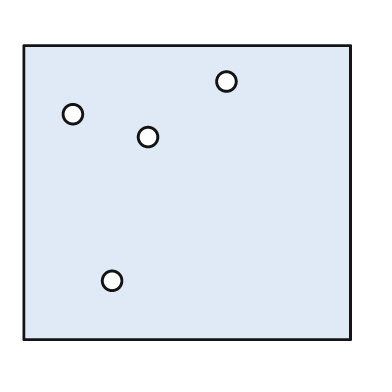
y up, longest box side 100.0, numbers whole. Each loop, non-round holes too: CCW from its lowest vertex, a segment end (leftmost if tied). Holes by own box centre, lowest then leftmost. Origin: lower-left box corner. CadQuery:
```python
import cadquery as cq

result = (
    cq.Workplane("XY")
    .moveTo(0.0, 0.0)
    .lineTo(100.0, 0.0)
    .lineTo(100.0, 90.0)
    .lineTo(0.0, 90.0)
    .close()
    .moveTo(27.0, 18.0)
    .circle(3.0)
    .moveTo(38.0, 62.0)
    .circle(3.0)
    .moveTo(15.0, 69.0)
    .circle(3.0)
    .moveTo(62.0, 79.0)
    .circle(3.0)
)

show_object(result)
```